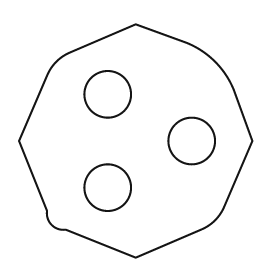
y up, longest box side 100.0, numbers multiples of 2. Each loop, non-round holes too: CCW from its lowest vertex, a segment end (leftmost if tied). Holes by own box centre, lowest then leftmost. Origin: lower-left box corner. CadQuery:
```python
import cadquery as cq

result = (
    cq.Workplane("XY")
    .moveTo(50.0, 0.0)
    .lineTo(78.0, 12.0)
    .threePointArc((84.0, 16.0), (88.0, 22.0))
    .lineTo(100.0, 50.0)
    .lineTo(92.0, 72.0)
    .threePointArc((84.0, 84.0), (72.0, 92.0))
    .lineTo(50.0, 100.0)
    .lineTo(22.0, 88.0)
    .threePointArc((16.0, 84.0), (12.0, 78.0))
    .lineTo(0.0, 50.0)
    .lineTo(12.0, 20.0)
    .threePointArc((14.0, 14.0), (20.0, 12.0))
    .close()
    .moveTo(38.0, 30.0)
    .circle(10.0)
    .moveTo(74.0, 50.0)
    .circle(10.0)
    .moveTo(38.0, 70.0)
    .circle(10.0)
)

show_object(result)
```